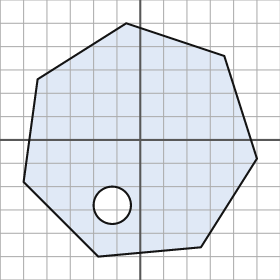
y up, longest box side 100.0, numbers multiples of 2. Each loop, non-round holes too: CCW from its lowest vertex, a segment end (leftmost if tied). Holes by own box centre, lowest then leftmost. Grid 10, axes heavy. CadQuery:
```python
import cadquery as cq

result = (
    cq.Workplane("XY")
    .moveTo(-18.0, -50.0)
    .lineTo(26.0, -46.0)
    .lineTo(50.0, -8.0)
    .lineTo(36.0, 36.0)
    .lineTo(-6.0, 50.0)
    .lineTo(-44.0, 26.0)
    .lineTo(-50.0, -18.0)
    .close()
    .moveTo(-12.0, -28.0)
    .circle(8.0)
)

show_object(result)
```